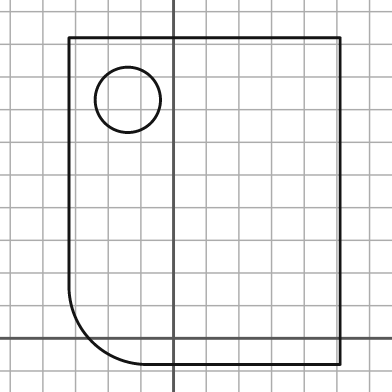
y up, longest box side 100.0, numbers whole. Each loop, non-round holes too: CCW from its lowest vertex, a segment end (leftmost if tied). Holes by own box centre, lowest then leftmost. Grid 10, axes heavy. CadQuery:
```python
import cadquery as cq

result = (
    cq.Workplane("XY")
    .moveTo(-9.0, -8.0)
    .lineTo(51.0, -8.0)
    .lineTo(51.0, 92.0)
    .lineTo(-32.0, 92.0)
    .lineTo(-32.0, 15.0)
    .threePointArc((-25.0, -1.0), (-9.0, -8.0))
    .close()
    .moveTo(-14.0, 73.0)
    .circle(10.0)
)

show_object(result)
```